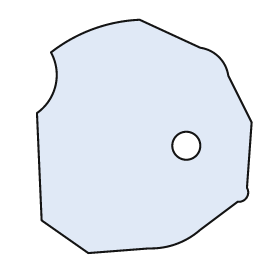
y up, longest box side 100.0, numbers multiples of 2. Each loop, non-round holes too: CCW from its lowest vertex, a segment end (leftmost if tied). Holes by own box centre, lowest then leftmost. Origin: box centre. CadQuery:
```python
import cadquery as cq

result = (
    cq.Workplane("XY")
    .moveTo(-24.0, -50.0)
    .lineTo(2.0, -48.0)
    .threePointArc((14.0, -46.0), (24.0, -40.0))
    .lineTo(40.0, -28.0)
    .threePointArc((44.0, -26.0), (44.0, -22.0))
    .lineTo(46.0, 6.0)
    .lineTo(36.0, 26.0)
    .threePointArc((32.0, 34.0), (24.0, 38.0))
    .lineTo(-2.0, 50.0)
    .threePointArc((-22.0, 46.0), (-40.0, 36.0))
    .threePointArc((-38.0, 22.0), (-46.0, 10.0))
    .lineTo(-44.0, -36.0)
    .close()
    .moveTo(18.0, -4.0)
    .circle(6.0)
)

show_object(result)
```